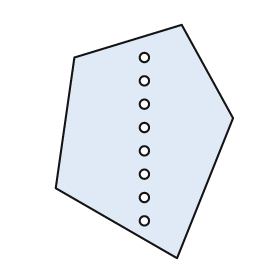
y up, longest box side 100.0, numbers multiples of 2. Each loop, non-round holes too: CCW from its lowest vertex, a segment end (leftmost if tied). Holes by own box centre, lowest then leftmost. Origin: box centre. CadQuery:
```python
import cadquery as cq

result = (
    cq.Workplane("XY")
    .moveTo(14.0, -50.0)
    .lineTo(38.0, 10.0)
    .lineTo(16.0, 50.0)
    .lineTo(-30.0, 36.0)
    .lineTo(-38.0, -20.0)
    .close()
    .moveTo(0.0, -34.0)
    .circle(2.0)
    .moveTo(0.0, -24.0)
    .circle(2.0)
    .moveTo(0.0, -14.0)
    .circle(2.0)
    .moveTo(0.0, -4.0)
    .circle(2.0)
    .moveTo(0.0, 6.0)
    .circle(2.0)
    .moveTo(0.0, 16.0)
    .circle(2.0)
    .moveTo(0.0, 26.0)
    .circle(2.0)
    .moveTo(0.0, 36.0)
    .circle(2.0)
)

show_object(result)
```